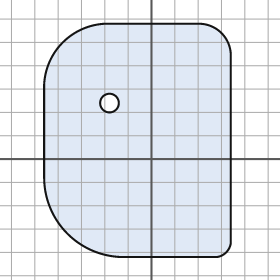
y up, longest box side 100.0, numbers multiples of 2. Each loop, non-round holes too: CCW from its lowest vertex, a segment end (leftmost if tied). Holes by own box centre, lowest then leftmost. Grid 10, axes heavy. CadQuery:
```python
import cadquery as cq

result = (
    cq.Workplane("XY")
    .moveTo(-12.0, -42.0)
    .lineTo(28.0, -42.0)
    .threePointArc((32.0, -40.0), (34.0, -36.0))
    .lineTo(34.0, 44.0)
    .threePointArc((30.0, 54.0), (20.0, 58.0))
    .lineTo(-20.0, 58.0)
    .threePointArc((-38.0, 50.0), (-46.0, 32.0))
    .lineTo(-46.0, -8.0)
    .threePointArc((-36.0, -32.0), (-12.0, -42.0))
    .close()
    .moveTo(-18.0, 24.0)
    .circle(4.0)
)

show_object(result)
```